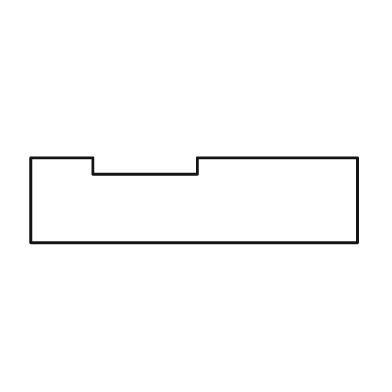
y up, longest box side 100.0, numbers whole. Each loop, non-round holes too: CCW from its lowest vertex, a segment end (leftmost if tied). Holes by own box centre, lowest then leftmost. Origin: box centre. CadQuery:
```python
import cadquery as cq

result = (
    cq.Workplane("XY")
    .moveTo(-50.0, -13.0)
    .lineTo(50.0, -13.0)
    .lineTo(50.0, 13.0)
    .lineTo(1.0, 13.0)
    .lineTo(1.0, 8.0)
    .lineTo(-31.0, 8.0)
    .lineTo(-31.0, 13.0)
    .lineTo(-50.0, 13.0)
    .close()
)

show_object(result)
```